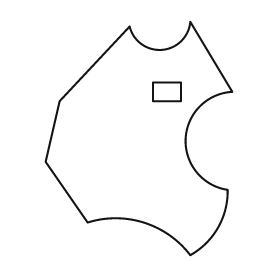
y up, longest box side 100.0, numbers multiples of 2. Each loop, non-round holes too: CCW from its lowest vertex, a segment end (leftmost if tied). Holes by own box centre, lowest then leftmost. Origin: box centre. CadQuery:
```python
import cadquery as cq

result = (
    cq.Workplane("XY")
    .moveTo(22.0, -50.0)
    .threePointArc((34.0, -38.0), (38.0, -22.0))
    .threePointArc((20.0, 0.0), (40.0, 20.0))
    .lineTo(22.0, 50.0)
    .threePointArc((10.0, 38.0), (-4.0, 48.0))
    .lineTo(-34.0, 16.0)
    .lineTo(-40.0, -10.0)
    .lineTo(-22.0, -36.0)
    .threePointArc((2.0, -36.0), (22.0, -50.0))
    .close()
    .moveTo(6.0, 16.0)
    .lineTo(18.0, 16.0)
    .lineTo(18.0, 24.0)
    .lineTo(6.0, 24.0)
    .close()
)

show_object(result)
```